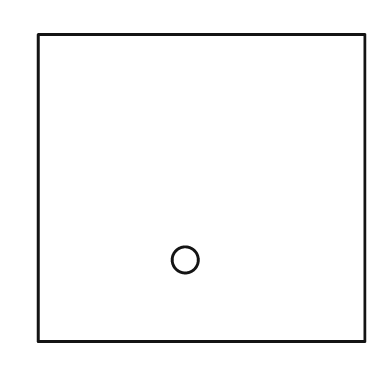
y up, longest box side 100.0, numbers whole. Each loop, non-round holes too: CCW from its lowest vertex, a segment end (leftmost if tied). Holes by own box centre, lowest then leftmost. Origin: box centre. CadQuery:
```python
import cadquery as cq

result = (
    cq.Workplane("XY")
    .moveTo(-50.0, -47.0)
    .lineTo(50.0, -47.0)
    .lineTo(50.0, 47.0)
    .lineTo(-50.0, 47.0)
    .close()
    .moveTo(-5.0, -22.0)
    .circle(4.0)
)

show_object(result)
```